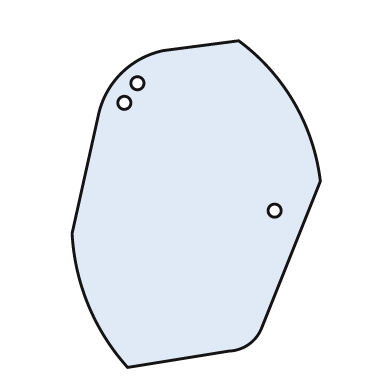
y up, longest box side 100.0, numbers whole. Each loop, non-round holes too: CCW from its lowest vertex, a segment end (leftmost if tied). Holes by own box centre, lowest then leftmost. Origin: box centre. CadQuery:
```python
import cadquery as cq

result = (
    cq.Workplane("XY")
    .moveTo(-21.0, -50.0)
    .lineTo(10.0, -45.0)
    .threePointArc((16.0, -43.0), (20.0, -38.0))
    .lineTo(38.0, 7.0)
    .threePointArc((30.0, 31.0), (13.0, 50.0))
    .lineTo(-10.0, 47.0)
    .threePointArc((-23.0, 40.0), (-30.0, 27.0))
    .lineTo(-38.0, -9.0)
    .threePointArc((-33.0, -31.0), (-21.0, -50.0))
    .close()
    .moveTo(24.0, -2.0)
    .circle(2.0)
    .moveTo(-22.0, 31.0)
    .circle(2.0)
    .moveTo(-18.0, 37.0)
    .circle(2.0)
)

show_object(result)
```